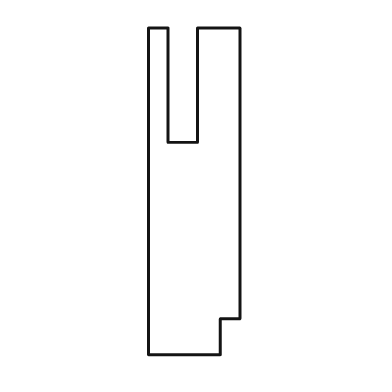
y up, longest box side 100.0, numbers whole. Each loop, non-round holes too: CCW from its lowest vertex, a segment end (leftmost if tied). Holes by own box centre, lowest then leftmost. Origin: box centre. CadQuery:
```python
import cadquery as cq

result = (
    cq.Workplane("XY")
    .moveTo(-14.0, -50.0)
    .lineTo(8.0, -50.0)
    .lineTo(8.0, -39.0)
    .lineTo(14.0, -39.0)
    .lineTo(14.0, 50.0)
    .lineTo(1.0, 50.0)
    .lineTo(1.0, 15.0)
    .lineTo(-8.0, 15.0)
    .lineTo(-8.0, 50.0)
    .lineTo(-14.0, 50.0)
    .close()
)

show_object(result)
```